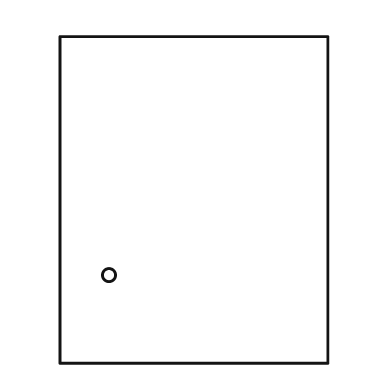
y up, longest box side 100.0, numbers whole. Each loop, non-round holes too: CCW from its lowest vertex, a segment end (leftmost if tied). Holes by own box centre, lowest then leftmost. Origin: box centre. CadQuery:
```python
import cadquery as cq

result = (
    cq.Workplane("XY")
    .moveTo(-41.0, -50.0)
    .lineTo(41.0, -50.0)
    .lineTo(41.0, 50.0)
    .lineTo(-41.0, 50.0)
    .close()
    .moveTo(-26.0, -23.0)
    .circle(2.0)
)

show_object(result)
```